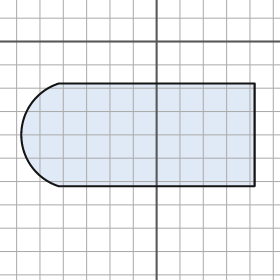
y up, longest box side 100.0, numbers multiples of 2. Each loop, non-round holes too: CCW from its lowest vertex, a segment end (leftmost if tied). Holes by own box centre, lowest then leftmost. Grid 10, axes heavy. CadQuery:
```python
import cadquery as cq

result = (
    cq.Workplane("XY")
    .moveTo(-42.0, -62.0)
    .lineTo(42.0, -62.0)
    .lineTo(42.0, -18.0)
    .lineTo(-42.0, -18.0)
    .threePointArc((-58.0, -40.0), (-42.0, -62.0))
    .close()
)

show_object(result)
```